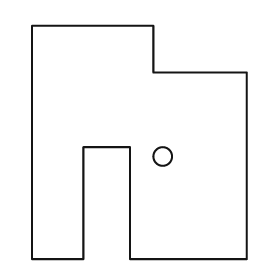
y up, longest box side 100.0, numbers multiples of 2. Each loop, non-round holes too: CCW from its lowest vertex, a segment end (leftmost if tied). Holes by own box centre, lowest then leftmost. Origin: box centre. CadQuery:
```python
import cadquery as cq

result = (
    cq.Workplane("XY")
    .moveTo(-46.0, -50.0)
    .lineTo(-24.0, -50.0)
    .lineTo(-24.0, -2.0)
    .lineTo(-4.0, -2.0)
    .lineTo(-4.0, -50.0)
    .lineTo(46.0, -50.0)
    .lineTo(46.0, 30.0)
    .lineTo(6.0, 30.0)
    .lineTo(6.0, 50.0)
    .lineTo(-46.0, 50.0)
    .close()
    .moveTo(10.0, -6.0)
    .circle(4.0)
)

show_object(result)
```